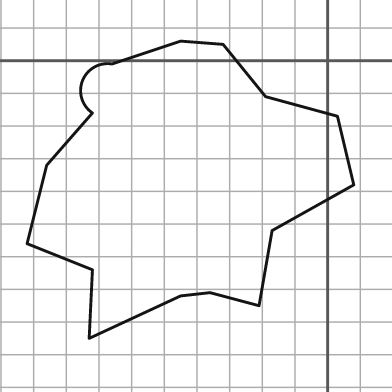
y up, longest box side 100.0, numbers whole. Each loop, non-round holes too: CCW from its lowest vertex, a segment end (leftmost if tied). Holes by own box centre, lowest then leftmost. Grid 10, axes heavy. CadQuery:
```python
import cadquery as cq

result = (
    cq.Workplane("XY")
    .moveTo(-73.0, -85.0)
    .lineTo(-45.0, -72.0)
    .lineTo(-36.0, -71.0)
    .lineTo(-21.0, -75.0)
    .lineTo(-17.0, -52.0)
    .lineTo(8.0, -38.0)
    .lineTo(3.0, -17.0)
    .lineTo(-19.0, -11.0)
    .lineTo(-32.0, 5.0)
    .lineTo(-45.0, 6.0)
    .lineTo(-66.0, -1.0)
    .threePointArc((-75.0, -6.0), (-72.0, -16.0))
    .lineTo(-86.0, -32.0)
    .lineTo(-92.0, -56.0)
    .lineTo(-72.0, -64.0)
    .close()
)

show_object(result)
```